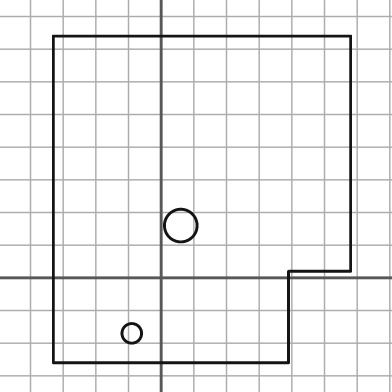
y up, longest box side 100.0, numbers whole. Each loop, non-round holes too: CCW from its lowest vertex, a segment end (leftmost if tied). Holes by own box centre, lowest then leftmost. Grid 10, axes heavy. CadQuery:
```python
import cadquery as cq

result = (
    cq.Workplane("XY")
    .moveTo(-33.0, -26.0)
    .lineTo(39.0, -26.0)
    .lineTo(39.0, 2.0)
    .lineTo(58.0, 2.0)
    .lineTo(58.0, 74.0)
    .lineTo(-33.0, 74.0)
    .close()
    .moveTo(-9.0, -17.0)
    .circle(3.0)
    .moveTo(6.0, 16.0)
    .circle(5.0)
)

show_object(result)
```